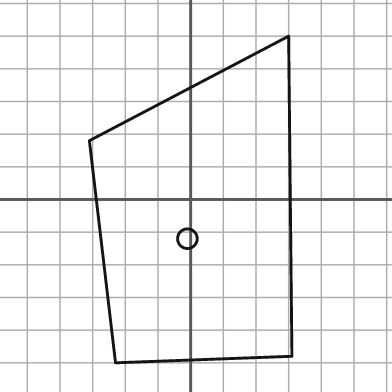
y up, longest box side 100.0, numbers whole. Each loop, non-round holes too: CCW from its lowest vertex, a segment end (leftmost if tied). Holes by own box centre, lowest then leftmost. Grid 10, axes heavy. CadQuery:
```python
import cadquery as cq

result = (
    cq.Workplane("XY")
    .moveTo(-23.0, -50.0)
    .lineTo(31.0, -48.0)
    .lineTo(30.0, 50.0)
    .lineTo(-31.0, 18.0)
    .close()
    .moveTo(-1.0, -12.0)
    .circle(3.0)
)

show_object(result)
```